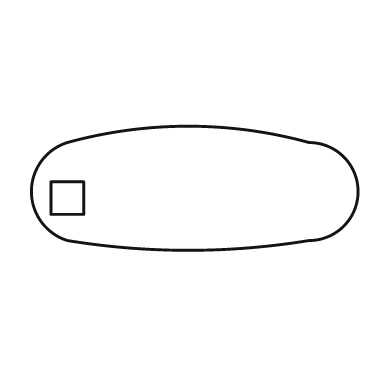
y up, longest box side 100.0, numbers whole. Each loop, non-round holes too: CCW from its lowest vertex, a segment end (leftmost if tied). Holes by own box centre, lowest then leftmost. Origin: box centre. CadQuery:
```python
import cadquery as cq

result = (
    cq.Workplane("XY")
    .moveTo(-39.0, -16.0)
    .threePointArc((-2.0, -19.0), (35.0, -16.0))
    .threePointArc((50.0, -1.0), (35.0, 14.0))
    .threePointArc((-2.0, 19.0), (-39.0, 14.0))
    .threePointArc((-50.0, -1.0), (-39.0, -16.0))
    .close()
    .moveTo(-44.0, -8.0)
    .lineTo(-34.0, -8.0)
    .lineTo(-34.0, 2.0)
    .lineTo(-44.0, 2.0)
    .close()
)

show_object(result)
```